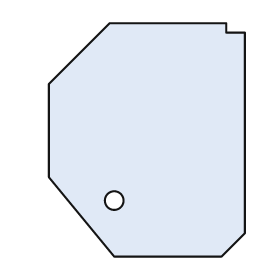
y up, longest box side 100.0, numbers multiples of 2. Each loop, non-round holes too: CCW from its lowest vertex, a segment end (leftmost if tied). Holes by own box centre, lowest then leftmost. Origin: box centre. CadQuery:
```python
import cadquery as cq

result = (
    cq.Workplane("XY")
    .moveTo(-14.0, -50.0)
    .lineTo(32.0, -50.0)
    .lineTo(42.0, -40.0)
    .lineTo(42.0, 46.0)
    .lineTo(34.0, 46.0)
    .lineTo(34.0, 50.0)
    .lineTo(-16.0, 50.0)
    .lineTo(-42.0, 24.0)
    .lineTo(-42.0, -16.0)
    .close()
    .moveTo(-14.0, -26.0)
    .circle(4.0)
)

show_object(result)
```